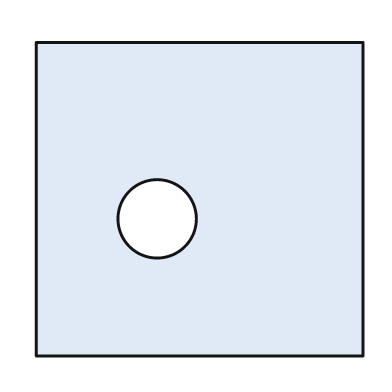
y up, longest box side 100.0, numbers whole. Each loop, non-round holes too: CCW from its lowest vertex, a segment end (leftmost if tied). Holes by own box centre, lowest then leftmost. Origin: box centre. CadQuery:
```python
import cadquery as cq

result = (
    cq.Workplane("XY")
    .moveTo(-50.0, -48.0)
    .lineTo(50.0, -48.0)
    .lineTo(50.0, 48.0)
    .lineTo(-50.0, 48.0)
    .close()
    .moveTo(-13.0, -6.0)
    .circle(12.0)
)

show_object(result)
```